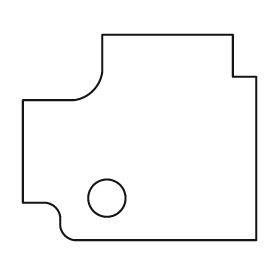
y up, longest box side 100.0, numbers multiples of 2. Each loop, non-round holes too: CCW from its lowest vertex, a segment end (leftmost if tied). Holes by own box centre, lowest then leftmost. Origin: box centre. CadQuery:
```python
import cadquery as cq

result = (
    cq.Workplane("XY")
    .moveTo(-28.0, -44.0)
    .lineTo(50.0, -44.0)
    .lineTo(50.0, 26.0)
    .lineTo(40.0, 26.0)
    .lineTo(40.0, 44.0)
    .lineTo(-16.0, 44.0)
    .lineTo(-16.0, 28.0)
    .threePointArc((-20.0, 20.0), (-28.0, 16.0))
    .lineTo(-50.0, 16.0)
    .lineTo(-50.0, -28.0)
    .lineTo(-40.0, -28.0)
    .threePointArc((-36.0, -30.0), (-34.0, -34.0))
    .lineTo(-34.0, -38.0)
    .threePointArc((-32.0, -42.0), (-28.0, -44.0))
    .close()
    .moveTo(-14.0, -26.0)
    .circle(8.0)
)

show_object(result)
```